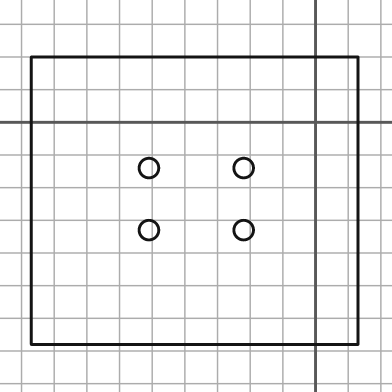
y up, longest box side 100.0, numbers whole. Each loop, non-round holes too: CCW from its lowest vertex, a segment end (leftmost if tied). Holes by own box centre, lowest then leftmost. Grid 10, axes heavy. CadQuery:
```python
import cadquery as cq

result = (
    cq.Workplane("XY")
    .moveTo(-87.0, -68.0)
    .lineTo(13.0, -68.0)
    .lineTo(13.0, 20.0)
    .lineTo(-87.0, 20.0)
    .close()
    .moveTo(-51.0, -33.0)
    .circle(3.0)
    .moveTo(-22.0, -33.0)
    .circle(3.0)
    .moveTo(-51.0, -14.0)
    .circle(3.0)
    .moveTo(-22.0, -14.0)
    .circle(3.0)
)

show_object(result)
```